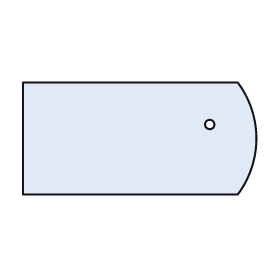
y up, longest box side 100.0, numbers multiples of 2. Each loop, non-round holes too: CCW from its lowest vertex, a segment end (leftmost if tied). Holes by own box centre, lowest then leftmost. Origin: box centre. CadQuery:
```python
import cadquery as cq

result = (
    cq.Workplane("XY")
    .moveTo(-50.0, -24.0)
    .lineTo(42.0, -24.0)
    .threePointArc((50.0, 0.0), (42.0, 24.0))
    .lineTo(-50.0, 24.0)
    .close()
    .moveTo(30.0, 6.0)
    .circle(2.0)
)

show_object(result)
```